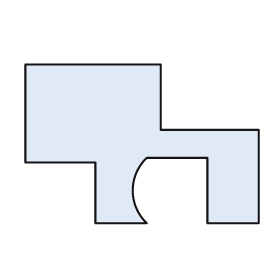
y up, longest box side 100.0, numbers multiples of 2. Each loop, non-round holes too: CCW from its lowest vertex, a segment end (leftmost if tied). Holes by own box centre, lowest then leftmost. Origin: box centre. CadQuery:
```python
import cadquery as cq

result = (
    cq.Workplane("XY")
    .moveTo(-20.0, -34.0)
    .lineTo(2.0, -34.0)
    .threePointArc((-4.0, -20.0), (2.0, -6.0))
    .lineTo(28.0, -6.0)
    .lineTo(28.0, -34.0)
    .lineTo(50.0, -34.0)
    .lineTo(50.0, 6.0)
    .lineTo(8.0, 6.0)
    .lineTo(8.0, 34.0)
    .lineTo(-50.0, 34.0)
    .lineTo(-50.0, -8.0)
    .lineTo(-20.0, -8.0)
    .close()
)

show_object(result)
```